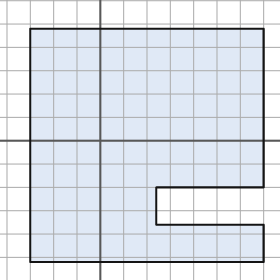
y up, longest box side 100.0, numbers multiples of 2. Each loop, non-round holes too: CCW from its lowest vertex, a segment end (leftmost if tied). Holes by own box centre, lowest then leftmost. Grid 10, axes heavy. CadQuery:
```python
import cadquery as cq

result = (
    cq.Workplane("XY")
    .moveTo(-30.0, -52.0)
    .lineTo(70.0, -52.0)
    .lineTo(70.0, -36.0)
    .lineTo(24.0, -36.0)
    .lineTo(24.0, -20.0)
    .lineTo(70.0, -20.0)
    .lineTo(70.0, 48.0)
    .lineTo(-30.0, 48.0)
    .close()
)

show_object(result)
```